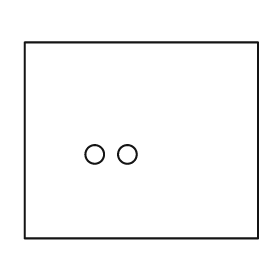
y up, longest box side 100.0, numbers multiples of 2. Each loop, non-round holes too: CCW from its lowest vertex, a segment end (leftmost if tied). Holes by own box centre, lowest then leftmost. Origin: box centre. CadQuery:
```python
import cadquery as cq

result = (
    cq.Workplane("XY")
    .moveTo(-50.0, -42.0)
    .lineTo(50.0, -42.0)
    .lineTo(50.0, 42.0)
    .lineTo(-50.0, 42.0)
    .close()
    .moveTo(-20.0, -6.0)
    .circle(4.0)
    .moveTo(-6.0, -6.0)
    .circle(4.0)
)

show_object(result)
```